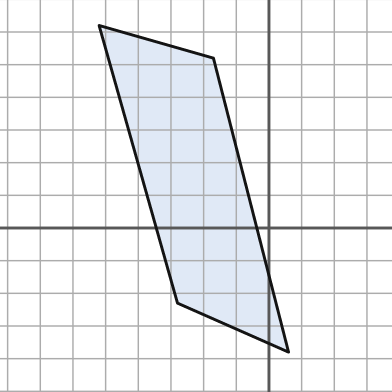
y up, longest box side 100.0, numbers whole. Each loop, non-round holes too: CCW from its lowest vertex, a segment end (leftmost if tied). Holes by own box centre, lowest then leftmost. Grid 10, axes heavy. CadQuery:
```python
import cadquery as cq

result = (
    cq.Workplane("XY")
    .moveTo(6.0, -38.0)
    .lineTo(-17.0, 52.0)
    .lineTo(-52.0, 62.0)
    .lineTo(-28.0, -23.0)
    .close()
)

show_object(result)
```